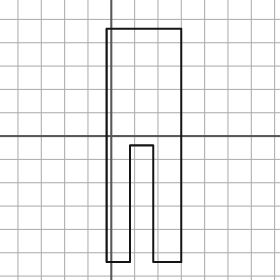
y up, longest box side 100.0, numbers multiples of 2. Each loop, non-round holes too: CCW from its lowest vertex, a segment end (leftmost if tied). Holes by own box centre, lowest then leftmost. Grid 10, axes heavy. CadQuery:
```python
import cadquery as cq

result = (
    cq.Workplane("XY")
    .moveTo(-2.0, -54.0)
    .lineTo(8.0, -54.0)
    .lineTo(8.0, -4.0)
    .lineTo(18.0, -4.0)
    .lineTo(18.0, -54.0)
    .lineTo(30.0, -54.0)
    .lineTo(30.0, 46.0)
    .lineTo(-2.0, 46.0)
    .close()
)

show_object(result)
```